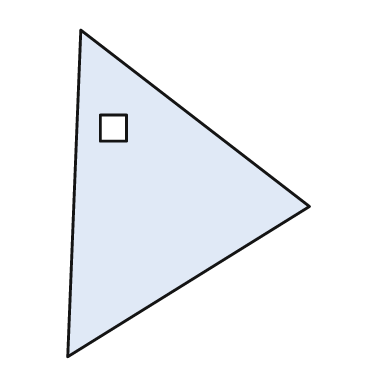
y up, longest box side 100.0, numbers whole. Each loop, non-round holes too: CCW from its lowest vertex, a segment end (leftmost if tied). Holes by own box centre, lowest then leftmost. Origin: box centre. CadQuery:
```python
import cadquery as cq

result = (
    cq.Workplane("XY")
    .moveTo(-37.0, -50.0)
    .lineTo(37.0, -4.0)
    .lineTo(-33.0, 50.0)
    .close()
    .moveTo(-27.0, 16.0)
    .lineTo(-19.0, 16.0)
    .lineTo(-19.0, 24.0)
    .lineTo(-27.0, 24.0)
    .close()
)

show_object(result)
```